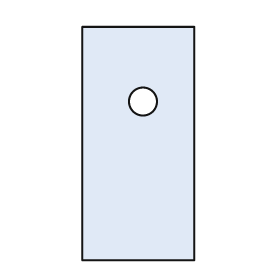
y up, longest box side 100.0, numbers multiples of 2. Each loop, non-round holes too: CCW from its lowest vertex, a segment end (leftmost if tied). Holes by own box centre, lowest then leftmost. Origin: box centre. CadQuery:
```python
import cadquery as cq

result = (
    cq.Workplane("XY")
    .moveTo(-24.0, -50.0)
    .lineTo(24.0, -50.0)
    .lineTo(24.0, 50.0)
    .lineTo(-24.0, 50.0)
    .close()
    .moveTo(2.0, 18.0)
    .circle(6.0)
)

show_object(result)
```